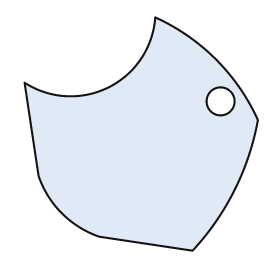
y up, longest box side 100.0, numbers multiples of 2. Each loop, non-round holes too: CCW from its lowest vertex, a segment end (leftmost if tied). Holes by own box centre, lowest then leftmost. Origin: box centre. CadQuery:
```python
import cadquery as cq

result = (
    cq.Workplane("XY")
    .moveTo(22.0, -50.0)
    .threePointArc((40.0, -24.0), (50.0, 6.0))
    .threePointArc((32.0, 32.0), (6.0, 50.0))
    .threePointArc((-14.0, 20.0), (-50.0, 22.0))
    .lineTo(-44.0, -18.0)
    .threePointArc((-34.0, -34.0), (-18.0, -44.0))
    .close()
    .moveTo(34.0, 14.0)
    .circle(6.0)
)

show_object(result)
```